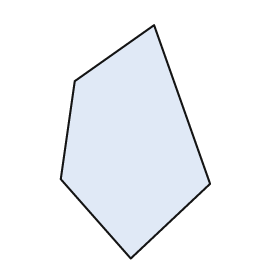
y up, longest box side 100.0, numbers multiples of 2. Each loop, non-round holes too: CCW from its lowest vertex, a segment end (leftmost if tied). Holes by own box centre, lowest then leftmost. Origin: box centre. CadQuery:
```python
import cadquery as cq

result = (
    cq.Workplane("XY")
    .moveTo(-2.0, -50.0)
    .lineTo(32.0, -18.0)
    .lineTo(8.0, 50.0)
    .lineTo(-26.0, 26.0)
    .lineTo(-32.0, -16.0)
    .close()
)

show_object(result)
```